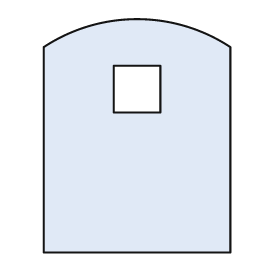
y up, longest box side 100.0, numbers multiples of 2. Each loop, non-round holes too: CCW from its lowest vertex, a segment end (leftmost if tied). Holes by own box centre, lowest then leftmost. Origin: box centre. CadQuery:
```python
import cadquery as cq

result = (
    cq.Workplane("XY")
    .moveTo(-40.0, -50.0)
    .lineTo(40.0, -50.0)
    .lineTo(40.0, 38.0)
    .threePointArc((0.0, 50.0), (-40.0, 38.0))
    .close()
    .moveTo(-10.0, 10.0)
    .lineTo(10.0, 10.0)
    .lineTo(10.0, 30.0)
    .lineTo(-10.0, 30.0)
    .close()
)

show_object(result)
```